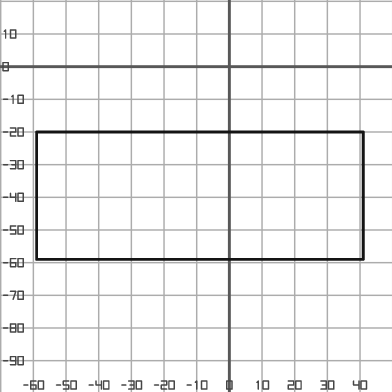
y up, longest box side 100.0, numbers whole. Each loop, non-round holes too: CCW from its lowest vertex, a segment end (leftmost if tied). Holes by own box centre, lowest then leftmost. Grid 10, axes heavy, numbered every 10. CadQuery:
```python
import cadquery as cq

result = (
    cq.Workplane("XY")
    .moveTo(-59.0, -59.0)
    .lineTo(41.0, -59.0)
    .lineTo(41.0, -20.0)
    .lineTo(-59.0, -20.0)
    .close()
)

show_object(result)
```